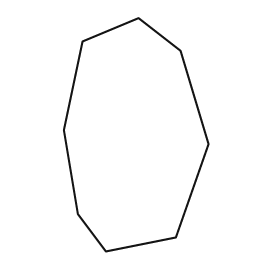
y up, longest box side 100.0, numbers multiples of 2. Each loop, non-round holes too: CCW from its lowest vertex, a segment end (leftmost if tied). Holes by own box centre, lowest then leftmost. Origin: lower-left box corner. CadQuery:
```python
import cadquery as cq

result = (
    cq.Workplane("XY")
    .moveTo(18.0, 0.0)
    .lineTo(48.0, 6.0)
    .lineTo(62.0, 46.0)
    .lineTo(50.0, 86.0)
    .lineTo(32.0, 100.0)
    .lineTo(8.0, 90.0)
    .lineTo(0.0, 52.0)
    .lineTo(6.0, 16.0)
    .close()
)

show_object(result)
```